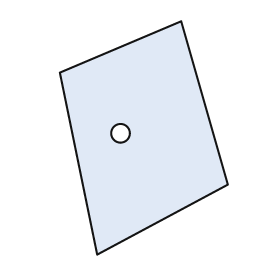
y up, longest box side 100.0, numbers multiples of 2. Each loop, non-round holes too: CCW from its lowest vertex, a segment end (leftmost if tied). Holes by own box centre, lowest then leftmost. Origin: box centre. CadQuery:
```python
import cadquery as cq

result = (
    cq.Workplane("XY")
    .moveTo(-20.0, -50.0)
    .lineTo(36.0, -20.0)
    .lineTo(16.0, 50.0)
    .lineTo(-36.0, 28.0)
    .close()
    .moveTo(-10.0, 2.0)
    .circle(4.0)
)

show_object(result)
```